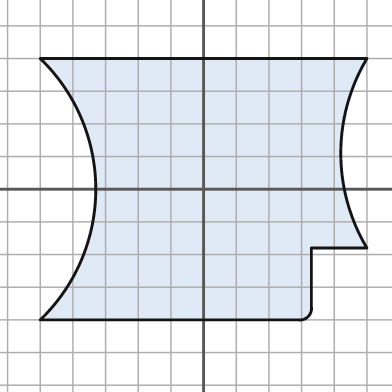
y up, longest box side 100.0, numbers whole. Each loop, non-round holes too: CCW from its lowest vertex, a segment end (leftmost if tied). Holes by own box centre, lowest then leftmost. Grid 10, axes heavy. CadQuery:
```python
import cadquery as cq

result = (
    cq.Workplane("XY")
    .moveTo(-50.0, -40.0)
    .lineTo(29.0, -40.0)
    .threePointArc((32.0, -39.0), (33.0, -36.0))
    .lineTo(33.0, -18.0)
    .lineTo(50.0, -18.0)
    .threePointArc((42.0, 11.0), (50.0, 40.0))
    .lineTo(-50.0, 40.0)
    .threePointArc((-33.0, 0.0), (-50.0, -40.0))
    .close()
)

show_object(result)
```